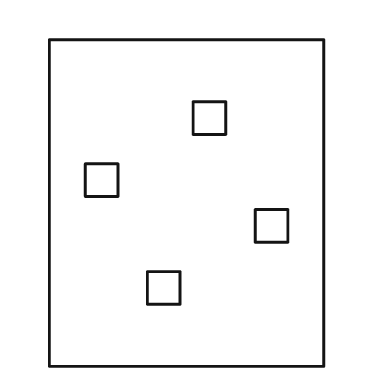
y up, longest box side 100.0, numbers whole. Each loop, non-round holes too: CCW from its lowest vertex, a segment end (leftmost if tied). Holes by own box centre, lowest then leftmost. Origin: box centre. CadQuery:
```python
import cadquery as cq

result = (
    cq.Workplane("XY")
    .moveTo(-42.0, -50.0)
    .lineTo(42.0, -50.0)
    .lineTo(42.0, 50.0)
    .lineTo(-42.0, 50.0)
    .close()
    .moveTo(-12.0, -31.0)
    .lineTo(-2.0, -31.0)
    .lineTo(-2.0, -21.0)
    .lineTo(-12.0, -21.0)
    .close()
    .moveTo(21.0, -12.0)
    .lineTo(31.0, -12.0)
    .lineTo(31.0, -2.0)
    .lineTo(21.0, -2.0)
    .close()
    .moveTo(-31.0, 2.0)
    .lineTo(-21.0, 2.0)
    .lineTo(-21.0, 12.0)
    .lineTo(-31.0, 12.0)
    .close()
    .moveTo(2.0, 21.0)
    .lineTo(12.0, 21.0)
    .lineTo(12.0, 31.0)
    .lineTo(2.0, 31.0)
    .close()
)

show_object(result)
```